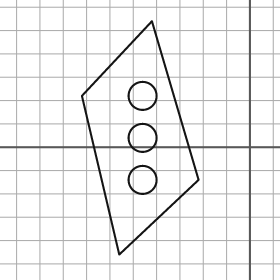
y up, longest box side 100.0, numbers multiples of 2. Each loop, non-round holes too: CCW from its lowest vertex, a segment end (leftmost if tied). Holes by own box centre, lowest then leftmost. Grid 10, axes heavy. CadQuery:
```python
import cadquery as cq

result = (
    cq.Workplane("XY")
    .moveTo(-56.0, -46.0)
    .lineTo(-22.0, -14.0)
    .lineTo(-42.0, 54.0)
    .lineTo(-72.0, 22.0)
    .close()
    .moveTo(-46.0, -14.0)
    .circle(6.0)
    .moveTo(-46.0, 4.0)
    .circle(6.0)
    .moveTo(-46.0, 22.0)
    .circle(6.0)
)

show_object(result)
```